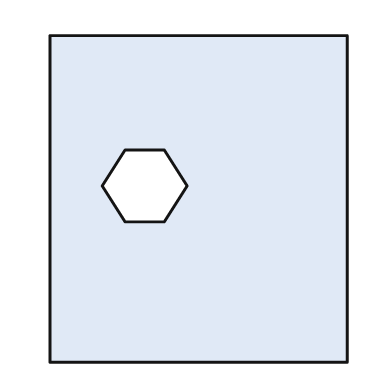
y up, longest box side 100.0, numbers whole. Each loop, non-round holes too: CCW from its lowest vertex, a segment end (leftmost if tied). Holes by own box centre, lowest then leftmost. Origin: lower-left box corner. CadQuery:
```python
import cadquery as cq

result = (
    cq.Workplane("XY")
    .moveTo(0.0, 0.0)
    .lineTo(91.0, 0.0)
    .lineTo(91.0, 100.0)
    .lineTo(0.0, 100.0)
    .close()
    .moveTo(23.0, 43.0)
    .lineTo(35.0, 43.0)
    .lineTo(42.0, 54.0)
    .lineTo(35.0, 65.0)
    .lineTo(23.0, 65.0)
    .lineTo(16.0, 54.0)
    .close()
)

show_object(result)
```